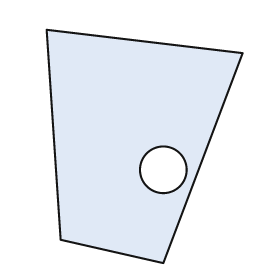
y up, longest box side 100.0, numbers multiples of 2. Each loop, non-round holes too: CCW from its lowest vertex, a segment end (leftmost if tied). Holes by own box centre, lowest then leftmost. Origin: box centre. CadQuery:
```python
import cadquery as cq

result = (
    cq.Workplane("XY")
    .moveTo(8.0, -50.0)
    .lineTo(42.0, 40.0)
    .lineTo(-42.0, 50.0)
    .lineTo(-36.0, -40.0)
    .close()
    .moveTo(8.0, -10.0)
    .circle(10.0)
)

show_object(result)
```